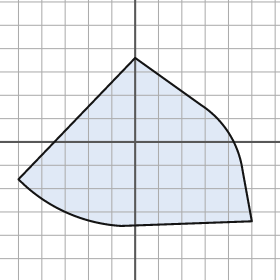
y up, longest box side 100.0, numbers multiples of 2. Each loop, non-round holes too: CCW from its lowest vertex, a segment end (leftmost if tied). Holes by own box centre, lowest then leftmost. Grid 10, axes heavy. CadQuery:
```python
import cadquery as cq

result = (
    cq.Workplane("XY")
    .moveTo(-6.0, -36.0)
    .lineTo(50.0, -34.0)
    .lineTo(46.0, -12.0)
    .threePointArc((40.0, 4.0), (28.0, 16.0))
    .lineTo(0.0, 36.0)
    .lineTo(-50.0, -16.0)
    .threePointArc((-30.0, -30.0), (-6.0, -36.0))
    .close()
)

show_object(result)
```